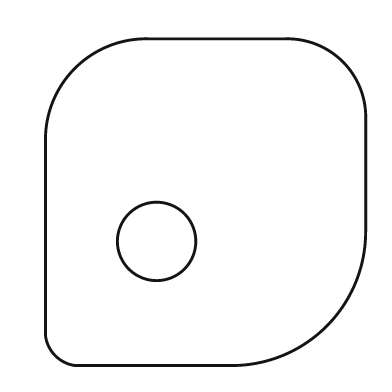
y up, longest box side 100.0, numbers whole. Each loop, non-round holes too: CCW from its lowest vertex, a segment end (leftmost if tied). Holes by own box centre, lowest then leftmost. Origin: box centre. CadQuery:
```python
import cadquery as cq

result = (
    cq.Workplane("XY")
    .moveTo(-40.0, -50.0)
    .lineTo(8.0, -50.0)
    .threePointArc((37.0, -38.0), (49.0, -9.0))
    .lineTo(49.0, 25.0)
    .threePointArc((42.0, 43.0), (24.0, 50.0))
    .lineTo(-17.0, 50.0)
    .threePointArc((-40.0, 41.0), (-49.0, 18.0))
    .lineTo(-49.0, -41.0)
    .threePointArc((-46.0, -47.0), (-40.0, -50.0))
    .close()
    .moveTo(-15.0, -12.0)
    .circle(12.0)
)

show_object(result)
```